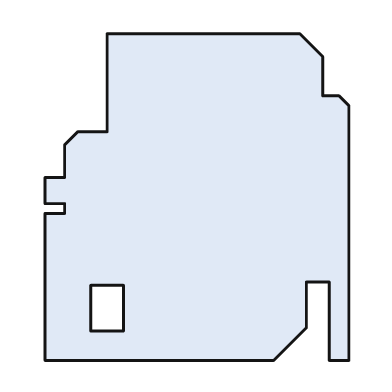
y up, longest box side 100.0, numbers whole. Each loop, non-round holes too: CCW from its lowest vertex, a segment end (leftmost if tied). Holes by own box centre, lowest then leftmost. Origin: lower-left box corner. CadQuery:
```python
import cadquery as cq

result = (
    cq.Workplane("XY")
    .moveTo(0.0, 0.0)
    .lineTo(70.0, 0.0)
    .lineTo(80.0, 10.0)
    .lineTo(80.0, 24.0)
    .lineTo(87.0, 24.0)
    .lineTo(87.0, 0.0)
    .lineTo(93.0, 0.0)
    .lineTo(93.0, 78.0)
    .lineTo(90.0, 81.0)
    .lineTo(85.0, 81.0)
    .lineTo(85.0, 93.0)
    .lineTo(78.0, 100.0)
    .lineTo(19.0, 100.0)
    .lineTo(19.0, 70.0)
    .lineTo(10.0, 70.0)
    .lineTo(6.0, 66.0)
    .lineTo(6.0, 56.0)
    .lineTo(0.0, 56.0)
    .lineTo(0.0, 48.0)
    .lineTo(6.0, 48.0)
    .lineTo(6.0, 45.0)
    .lineTo(0.0, 45.0)
    .close()
    .moveTo(14.0, 9.0)
    .lineTo(24.0, 9.0)
    .lineTo(24.0, 23.0)
    .lineTo(14.0, 23.0)
    .close()
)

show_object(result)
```